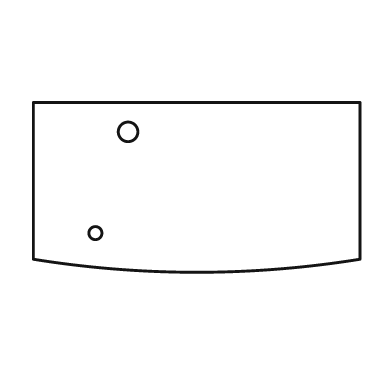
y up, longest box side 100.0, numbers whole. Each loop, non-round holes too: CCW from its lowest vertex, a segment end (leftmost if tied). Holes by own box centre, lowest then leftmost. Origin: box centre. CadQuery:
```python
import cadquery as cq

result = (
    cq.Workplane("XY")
    .moveTo(-50.0, -22.0)
    .threePointArc((0.0, -26.0), (50.0, -22.0))
    .lineTo(50.0, 26.0)
    .lineTo(-50.0, 26.0)
    .close()
    .moveTo(-31.0, -14.0)
    .circle(2.0)
    .moveTo(-21.0, 17.0)
    .circle(3.0)
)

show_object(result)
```